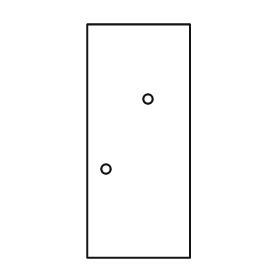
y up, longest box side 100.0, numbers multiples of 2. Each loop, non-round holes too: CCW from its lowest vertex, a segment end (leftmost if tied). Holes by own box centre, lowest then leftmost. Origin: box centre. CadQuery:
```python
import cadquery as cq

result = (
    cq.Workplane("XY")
    .moveTo(-22.0, -50.0)
    .lineTo(22.0, -50.0)
    .lineTo(22.0, 50.0)
    .lineTo(-22.0, 50.0)
    .close()
    .moveTo(-14.0, -12.0)
    .circle(2.0)
    .moveTo(4.0, 18.0)
    .circle(2.0)
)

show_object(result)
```